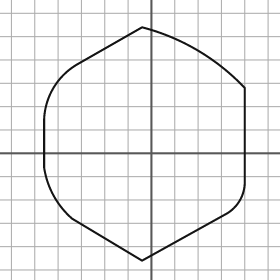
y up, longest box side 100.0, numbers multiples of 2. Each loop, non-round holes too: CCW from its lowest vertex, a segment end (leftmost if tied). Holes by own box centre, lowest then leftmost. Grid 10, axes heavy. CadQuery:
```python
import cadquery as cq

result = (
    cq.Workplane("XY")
    .moveTo(-4.0, -46.0)
    .lineTo(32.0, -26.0)
    .threePointArc((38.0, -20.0), (40.0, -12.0))
    .lineTo(40.0, 28.0)
    .threePointArc((20.0, 44.0), (-4.0, 54.0))
    .lineTo(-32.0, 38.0)
    .threePointArc((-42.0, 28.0), (-46.0, 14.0))
    .lineTo(-46.0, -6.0)
    .threePointArc((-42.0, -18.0), (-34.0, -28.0))
    .close()
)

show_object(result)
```